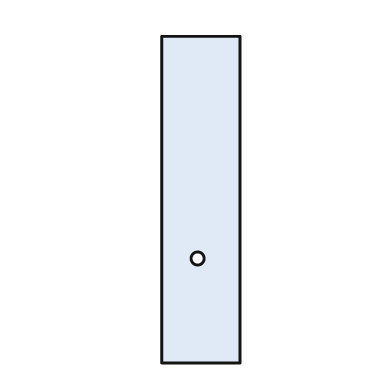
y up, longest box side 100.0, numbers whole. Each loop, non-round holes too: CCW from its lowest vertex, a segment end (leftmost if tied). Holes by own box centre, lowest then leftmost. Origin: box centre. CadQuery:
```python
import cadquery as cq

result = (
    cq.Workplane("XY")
    .moveTo(-12.0, -50.0)
    .lineTo(12.0, -50.0)
    .lineTo(12.0, 50.0)
    .lineTo(-12.0, 50.0)
    .close()
    .moveTo(-1.0, -18.0)
    .circle(2.0)
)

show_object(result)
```